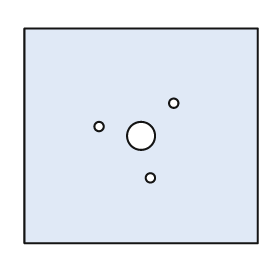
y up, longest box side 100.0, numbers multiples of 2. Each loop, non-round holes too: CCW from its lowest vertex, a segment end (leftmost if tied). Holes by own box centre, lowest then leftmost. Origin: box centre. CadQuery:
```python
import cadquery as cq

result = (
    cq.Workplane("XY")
    .moveTo(-50.0, -46.0)
    .lineTo(50.0, -46.0)
    .lineTo(50.0, 46.0)
    .lineTo(-50.0, 46.0)
    .close()
    .moveTo(4.0, -18.0)
    .circle(2.0)
    .moveTo(0.0, 0.0)
    .circle(6.0)
    .moveTo(-18.0, 4.0)
    .circle(2.0)
    .moveTo(14.0, 14.0)
    .circle(2.0)
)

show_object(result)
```